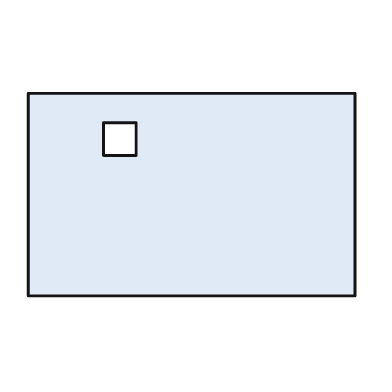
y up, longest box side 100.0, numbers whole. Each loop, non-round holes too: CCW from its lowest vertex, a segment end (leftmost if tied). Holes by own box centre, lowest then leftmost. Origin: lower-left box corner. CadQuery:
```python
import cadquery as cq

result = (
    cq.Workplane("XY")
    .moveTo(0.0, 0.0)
    .lineTo(100.0, 0.0)
    .lineTo(100.0, 62.0)
    .lineTo(0.0, 62.0)
    .close()
    .moveTo(23.0, 43.0)
    .lineTo(33.0, 43.0)
    .lineTo(33.0, 53.0)
    .lineTo(23.0, 53.0)
    .close()
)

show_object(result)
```